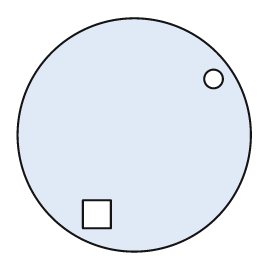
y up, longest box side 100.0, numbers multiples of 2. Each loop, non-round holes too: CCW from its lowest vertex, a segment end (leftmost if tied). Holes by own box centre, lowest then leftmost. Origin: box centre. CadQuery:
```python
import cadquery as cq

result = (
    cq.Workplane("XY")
    .moveTo(0.0, 0.0)
    .circle(50.0)
    .moveTo(-22.0, -40.0)
    .lineTo(-10.0, -40.0)
    .lineTo(-10.0, -28.0)
    .lineTo(-22.0, -28.0)
    .close()
    .moveTo(34.0, 24.0)
    .circle(4.0)
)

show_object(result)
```